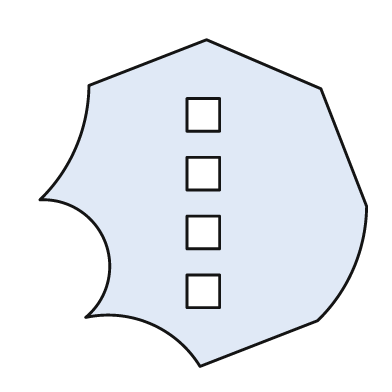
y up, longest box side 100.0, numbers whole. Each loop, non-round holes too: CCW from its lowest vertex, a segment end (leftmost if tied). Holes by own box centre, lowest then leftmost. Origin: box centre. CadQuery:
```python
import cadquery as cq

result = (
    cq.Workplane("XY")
    .moveTo(-1.0, -50.0)
    .lineTo(35.0, -36.0)
    .threePointArc((46.0, -20.0), (50.0, -1.0))
    .lineTo(36.0, 35.0)
    .lineTo(1.0, 50.0)
    .lineTo(-35.0, 36.0)
    .threePointArc((-39.0, 17.0), (-50.0, 1.0))
    .threePointArc((-30.0, -12.0), (-36.0, -35.0))
    .threePointArc((-16.0, -37.0), (-1.0, -50.0))
    .close()
    .moveTo(-5.0, -32.0)
    .lineTo(5.0, -32.0)
    .lineTo(5.0, -22.0)
    .lineTo(-5.0, -22.0)
    .close()
    .moveTo(-5.0, -14.0)
    .lineTo(5.0, -14.0)
    .lineTo(5.0, -4.0)
    .lineTo(-5.0, -4.0)
    .close()
    .moveTo(-5.0, 4.0)
    .lineTo(5.0, 4.0)
    .lineTo(5.0, 14.0)
    .lineTo(-5.0, 14.0)
    .close()
    .moveTo(-5.0, 22.0)
    .lineTo(5.0, 22.0)
    .lineTo(5.0, 32.0)
    .lineTo(-5.0, 32.0)
    .close()
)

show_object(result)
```